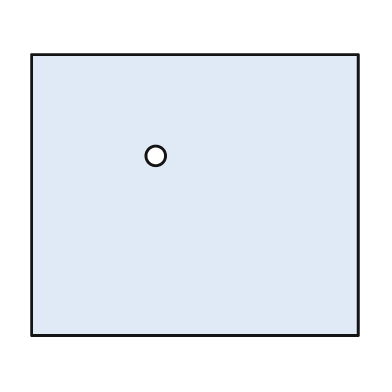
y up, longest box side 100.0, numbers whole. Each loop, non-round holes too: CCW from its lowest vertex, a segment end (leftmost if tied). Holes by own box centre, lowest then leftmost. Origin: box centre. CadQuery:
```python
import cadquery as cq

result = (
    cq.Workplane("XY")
    .moveTo(-50.0, -43.0)
    .lineTo(50.0, -43.0)
    .lineTo(50.0, 43.0)
    .lineTo(-50.0, 43.0)
    .close()
    .moveTo(-12.0, 12.0)
    .circle(3.0)
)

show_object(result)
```